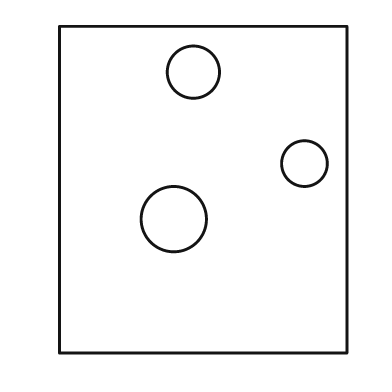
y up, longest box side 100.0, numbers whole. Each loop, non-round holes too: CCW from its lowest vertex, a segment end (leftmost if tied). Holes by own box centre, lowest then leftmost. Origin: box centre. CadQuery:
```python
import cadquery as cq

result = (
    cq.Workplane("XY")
    .moveTo(-44.0, -50.0)
    .lineTo(44.0, -50.0)
    .lineTo(44.0, 50.0)
    .lineTo(-44.0, 50.0)
    .close()
    .moveTo(-9.0, -9.0)
    .circle(10.0)
    .moveTo(31.0, 8.0)
    .circle(7.0)
    .moveTo(-3.0, 36.0)
    .circle(8.0)
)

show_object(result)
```